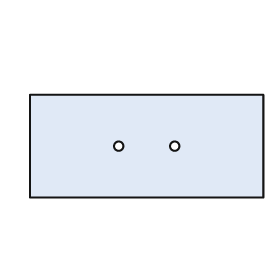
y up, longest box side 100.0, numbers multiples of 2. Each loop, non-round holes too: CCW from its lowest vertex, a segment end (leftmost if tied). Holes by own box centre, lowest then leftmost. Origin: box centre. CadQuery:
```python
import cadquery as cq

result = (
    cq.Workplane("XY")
    .moveTo(-50.0, -22.0)
    .lineTo(50.0, -22.0)
    .lineTo(50.0, 22.0)
    .lineTo(-50.0, 22.0)
    .close()
    .moveTo(-12.0, 0.0)
    .circle(2.0)
    .moveTo(12.0, 0.0)
    .circle(2.0)
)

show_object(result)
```